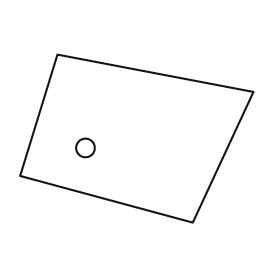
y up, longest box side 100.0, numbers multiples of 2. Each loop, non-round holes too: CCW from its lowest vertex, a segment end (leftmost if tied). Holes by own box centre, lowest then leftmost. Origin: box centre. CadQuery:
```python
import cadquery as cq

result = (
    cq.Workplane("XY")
    .moveTo(24.0, -36.0)
    .lineTo(50.0, 20.0)
    .lineTo(-34.0, 36.0)
    .lineTo(-50.0, -16.0)
    .close()
    .moveTo(-22.0, -4.0)
    .circle(4.0)
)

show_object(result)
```